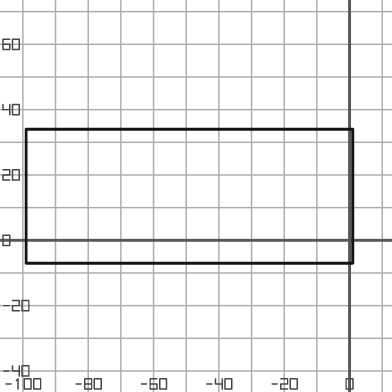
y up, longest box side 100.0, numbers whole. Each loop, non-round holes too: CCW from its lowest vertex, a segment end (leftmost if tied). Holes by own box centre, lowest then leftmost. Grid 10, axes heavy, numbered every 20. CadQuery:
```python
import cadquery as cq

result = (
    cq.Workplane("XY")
    .moveTo(-99.0, -7.0)
    .lineTo(1.0, -7.0)
    .lineTo(1.0, 34.0)
    .lineTo(-99.0, 34.0)
    .close()
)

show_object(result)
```